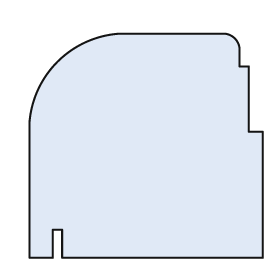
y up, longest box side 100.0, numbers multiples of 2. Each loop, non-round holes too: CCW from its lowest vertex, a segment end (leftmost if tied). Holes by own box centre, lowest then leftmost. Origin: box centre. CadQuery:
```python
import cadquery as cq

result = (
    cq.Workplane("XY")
    .moveTo(-50.0, -48.0)
    .lineTo(-40.0, -48.0)
    .lineTo(-40.0, -36.0)
    .lineTo(-36.0, -36.0)
    .lineTo(-36.0, -48.0)
    .lineTo(50.0, -48.0)
    .lineTo(50.0, 6.0)
    .lineTo(44.0, 6.0)
    .lineTo(44.0, 34.0)
    .lineTo(40.0, 34.0)
    .lineTo(40.0, 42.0)
    .threePointArc((38.0, 46.0), (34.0, 48.0))
    .lineTo(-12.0, 48.0)
    .threePointArc((-38.0, 36.0), (-50.0, 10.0))
    .close()
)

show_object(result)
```